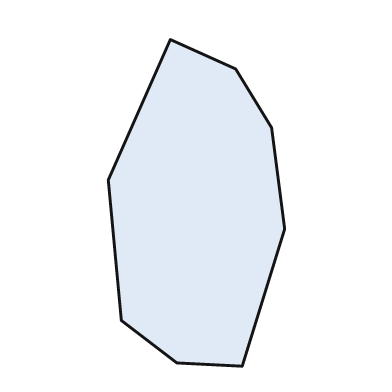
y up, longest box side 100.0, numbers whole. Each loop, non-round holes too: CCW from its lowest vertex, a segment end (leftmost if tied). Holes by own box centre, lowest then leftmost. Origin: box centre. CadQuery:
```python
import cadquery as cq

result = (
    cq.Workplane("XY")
    .moveTo(14.0, -50.0)
    .lineTo(27.0, -8.0)
    .lineTo(23.0, 23.0)
    .lineTo(12.0, 41.0)
    .lineTo(-8.0, 50.0)
    .lineTo(-27.0, 7.0)
    .lineTo(-23.0, -36.0)
    .lineTo(-6.0, -49.0)
    .close()
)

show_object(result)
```